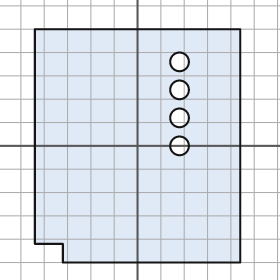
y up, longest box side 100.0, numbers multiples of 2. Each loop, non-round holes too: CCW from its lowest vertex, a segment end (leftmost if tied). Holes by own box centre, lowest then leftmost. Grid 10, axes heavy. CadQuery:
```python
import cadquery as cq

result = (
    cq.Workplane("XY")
    .moveTo(-32.0, -50.0)
    .lineTo(44.0, -50.0)
    .lineTo(44.0, 50.0)
    .lineTo(-44.0, 50.0)
    .lineTo(-44.0, -42.0)
    .lineTo(-32.0, -42.0)
    .close()
    .moveTo(18.0, 0.0)
    .circle(4.0)
    .moveTo(18.0, 12.0)
    .circle(4.0)
    .moveTo(18.0, 24.0)
    .circle(4.0)
    .moveTo(18.0, 36.0)
    .circle(4.0)
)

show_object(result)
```